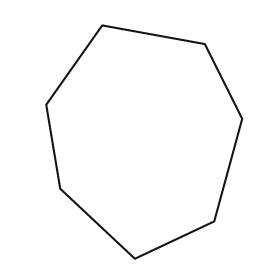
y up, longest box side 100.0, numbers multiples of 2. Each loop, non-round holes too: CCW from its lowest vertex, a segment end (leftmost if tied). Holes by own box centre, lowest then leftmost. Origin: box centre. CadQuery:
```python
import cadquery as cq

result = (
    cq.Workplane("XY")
    .moveTo(-4.0, -50.0)
    .lineTo(30.0, -34.0)
    .lineTo(42.0, 10.0)
    .lineTo(26.0, 42.0)
    .lineTo(-18.0, 50.0)
    .lineTo(-42.0, 16.0)
    .lineTo(-36.0, -20.0)
    .close()
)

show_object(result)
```